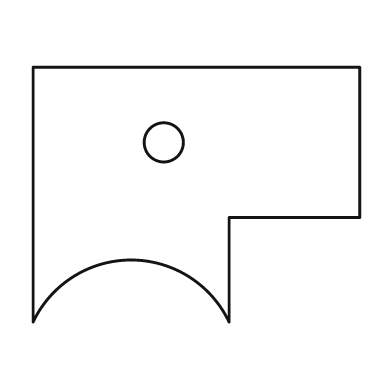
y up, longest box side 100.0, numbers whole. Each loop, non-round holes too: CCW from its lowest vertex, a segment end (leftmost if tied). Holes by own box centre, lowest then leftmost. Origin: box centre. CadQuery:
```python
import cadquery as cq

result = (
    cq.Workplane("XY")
    .moveTo(-50.0, -39.0)
    .threePointArc((-20.0, -20.0), (10.0, -39.0))
    .lineTo(10.0, -7.0)
    .lineTo(50.0, -7.0)
    .lineTo(50.0, 39.0)
    .lineTo(-50.0, 39.0)
    .close()
    .moveTo(-10.0, 16.0)
    .circle(6.0)
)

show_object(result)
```